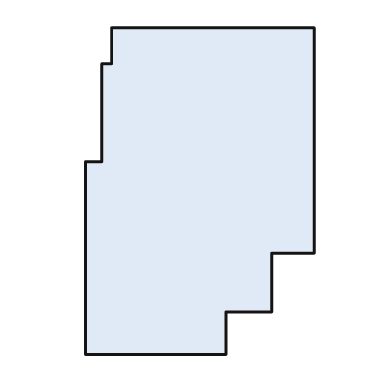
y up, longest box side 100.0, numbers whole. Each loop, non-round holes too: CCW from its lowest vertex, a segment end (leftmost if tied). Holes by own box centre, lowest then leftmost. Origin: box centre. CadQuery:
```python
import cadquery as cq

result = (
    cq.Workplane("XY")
    .moveTo(-35.0, -50.0)
    .lineTo(8.0, -50.0)
    .lineTo(8.0, -37.0)
    .lineTo(22.0, -37.0)
    .lineTo(22.0, -19.0)
    .lineTo(35.0, -19.0)
    .lineTo(35.0, 50.0)
    .lineTo(-27.0, 50.0)
    .lineTo(-27.0, 39.0)
    .lineTo(-30.0, 39.0)
    .lineTo(-30.0, 9.0)
    .lineTo(-35.0, 9.0)
    .close()
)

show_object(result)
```